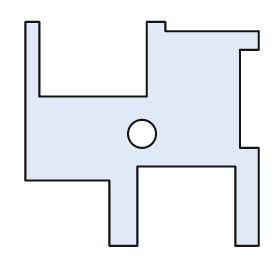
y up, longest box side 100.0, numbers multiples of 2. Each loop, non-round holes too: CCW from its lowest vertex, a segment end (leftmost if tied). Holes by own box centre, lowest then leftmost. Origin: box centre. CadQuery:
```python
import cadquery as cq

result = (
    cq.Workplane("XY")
    .moveTo(-14.0, -48.0)
    .lineTo(-2.0, -48.0)
    .lineTo(-2.0, -14.0)
    .lineTo(40.0, -14.0)
    .lineTo(40.0, -48.0)
    .lineTo(50.0, -48.0)
    .lineTo(50.0, -6.0)
    .lineTo(42.0, -6.0)
    .lineTo(42.0, 36.0)
    .lineTo(50.0, 36.0)
    .lineTo(50.0, 44.0)
    .lineTo(10.0, 44.0)
    .lineTo(10.0, 48.0)
    .lineTo(2.0, 48.0)
    .lineTo(2.0, 16.0)
    .lineTo(-44.0, 16.0)
    .lineTo(-44.0, 48.0)
    .lineTo(-50.0, 48.0)
    .lineTo(-50.0, -20.0)
    .lineTo(-14.0, -20.0)
    .close()
    .moveTo(0.0, 0.0)
    .circle(6.0)
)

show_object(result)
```